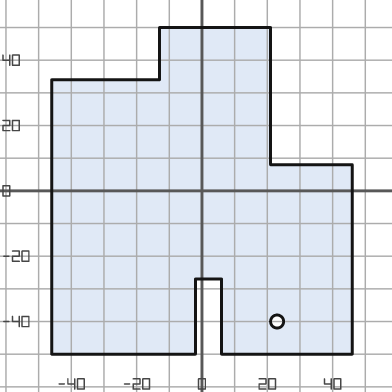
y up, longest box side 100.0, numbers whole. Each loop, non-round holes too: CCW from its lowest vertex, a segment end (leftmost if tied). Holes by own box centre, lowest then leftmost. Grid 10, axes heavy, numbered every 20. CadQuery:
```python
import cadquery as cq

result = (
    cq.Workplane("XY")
    .moveTo(-46.0, -50.0)
    .lineTo(-2.0, -50.0)
    .lineTo(-2.0, -27.0)
    .lineTo(6.0, -27.0)
    .lineTo(6.0, -50.0)
    .lineTo(46.0, -50.0)
    .lineTo(46.0, 8.0)
    .lineTo(21.0, 8.0)
    .lineTo(21.0, 50.0)
    .lineTo(-13.0, 50.0)
    .lineTo(-13.0, 34.0)
    .lineTo(-46.0, 34.0)
    .close()
    .moveTo(23.0, -40.0)
    .circle(2.0)
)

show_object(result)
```